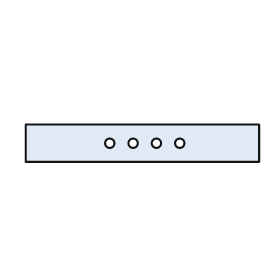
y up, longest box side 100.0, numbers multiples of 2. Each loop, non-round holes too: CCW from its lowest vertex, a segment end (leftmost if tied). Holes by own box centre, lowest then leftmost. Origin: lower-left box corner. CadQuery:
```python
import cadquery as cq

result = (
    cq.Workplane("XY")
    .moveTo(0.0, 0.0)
    .lineTo(100.0, 0.0)
    .lineTo(100.0, 16.0)
    .lineTo(0.0, 16.0)
    .close()
    .moveTo(36.0, 8.0)
    .circle(2.0)
    .moveTo(46.0, 8.0)
    .circle(2.0)
    .moveTo(56.0, 8.0)
    .circle(2.0)
    .moveTo(66.0, 8.0)
    .circle(2.0)
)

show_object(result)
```